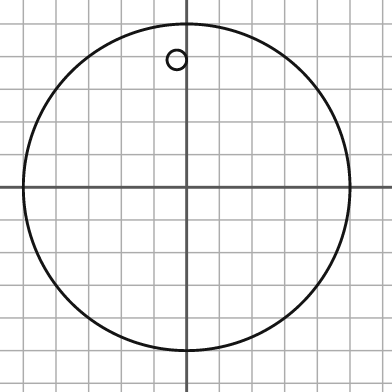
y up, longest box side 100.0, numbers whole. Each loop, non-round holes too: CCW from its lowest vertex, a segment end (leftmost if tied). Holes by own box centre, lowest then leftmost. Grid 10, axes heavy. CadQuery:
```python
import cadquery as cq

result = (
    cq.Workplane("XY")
    .moveTo(0.0, 0.0)
    .circle(50.0)
    .moveTo(-3.0, 39.0)
    .circle(3.0)
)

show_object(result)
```